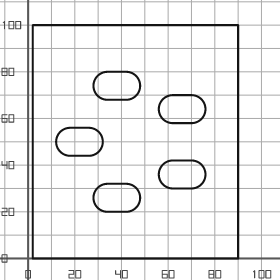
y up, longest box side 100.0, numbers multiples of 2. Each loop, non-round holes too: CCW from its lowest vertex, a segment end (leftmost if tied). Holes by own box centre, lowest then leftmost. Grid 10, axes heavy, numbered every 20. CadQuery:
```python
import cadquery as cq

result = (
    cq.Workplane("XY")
    .moveTo(2.0, 0.0)
    .lineTo(90.0, 0.0)
    .lineTo(90.0, 100.0)
    .lineTo(2.0, 100.0)
    .close()
    .moveTo(34.0, 20.0)
    .lineTo(42.0, 20.0)
    .threePointArc((48.0, 26.0), (42.0, 32.0))
    .lineTo(34.0, 32.0)
    .threePointArc((28.0, 26.0), (34.0, 20.0))
    .close()
    .moveTo(62.0, 30.0)
    .lineTo(70.0, 30.0)
    .threePointArc((76.0, 36.0), (70.0, 42.0))
    .lineTo(62.0, 42.0)
    .threePointArc((56.0, 36.0), (62.0, 30.0))
    .close()
    .moveTo(18.0, 44.0)
    .lineTo(26.0, 44.0)
    .threePointArc((32.0, 50.0), (26.0, 56.0))
    .lineTo(18.0, 56.0)
    .threePointArc((12.0, 50.0), (18.0, 44.0))
    .close()
    .moveTo(62.0, 58.0)
    .lineTo(70.0, 58.0)
    .threePointArc((76.0, 64.0), (70.0, 70.0))
    .lineTo(62.0, 70.0)
    .threePointArc((56.0, 64.0), (62.0, 58.0))
    .close()
    .moveTo(34.0, 68.0)
    .lineTo(42.0, 68.0)
    .threePointArc((48.0, 74.0), (42.0, 80.0))
    .lineTo(34.0, 80.0)
    .threePointArc((28.0, 74.0), (34.0, 68.0))
    .close()
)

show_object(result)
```